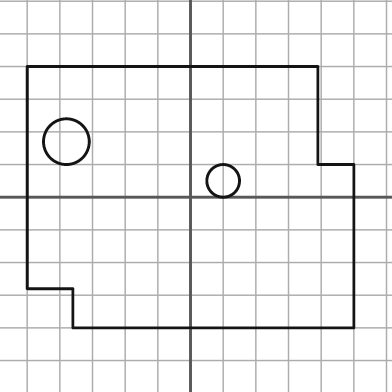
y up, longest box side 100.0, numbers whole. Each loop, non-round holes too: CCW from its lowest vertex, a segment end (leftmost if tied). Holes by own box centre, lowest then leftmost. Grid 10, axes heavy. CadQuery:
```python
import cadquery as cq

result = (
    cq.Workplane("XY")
    .moveTo(-36.0, -40.0)
    .lineTo(50.0, -40.0)
    .lineTo(50.0, 10.0)
    .lineTo(39.0, 10.0)
    .lineTo(39.0, 40.0)
    .lineTo(-50.0, 40.0)
    .lineTo(-50.0, -28.0)
    .lineTo(-36.0, -28.0)
    .close()
    .moveTo(10.0, 5.0)
    .circle(5.0)
    .moveTo(-38.0, 17.0)
    .circle(7.0)
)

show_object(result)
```